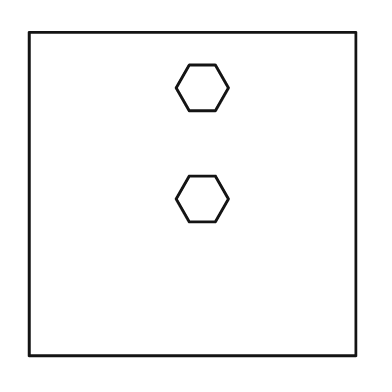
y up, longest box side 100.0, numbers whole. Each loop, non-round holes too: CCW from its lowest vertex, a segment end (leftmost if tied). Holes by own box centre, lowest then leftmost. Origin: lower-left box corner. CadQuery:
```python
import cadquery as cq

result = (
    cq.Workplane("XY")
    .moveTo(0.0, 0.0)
    .lineTo(100.0, 0.0)
    .lineTo(100.0, 99.0)
    .lineTo(0.0, 99.0)
    .close()
    .moveTo(49.0, 41.0)
    .lineTo(57.0, 41.0)
    .lineTo(61.0, 48.0)
    .lineTo(57.0, 55.0)
    .lineTo(49.0, 55.0)
    .lineTo(45.0, 48.0)
    .close()
    .moveTo(49.0, 75.0)
    .lineTo(57.0, 75.0)
    .lineTo(61.0, 82.0)
    .lineTo(57.0, 89.0)
    .lineTo(49.0, 89.0)
    .lineTo(45.0, 82.0)
    .close()
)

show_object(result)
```